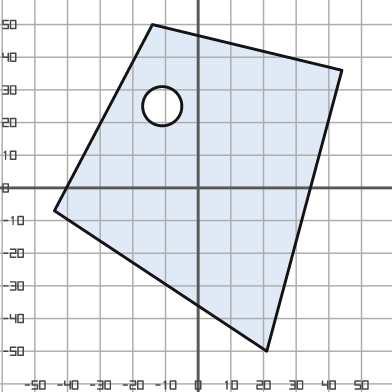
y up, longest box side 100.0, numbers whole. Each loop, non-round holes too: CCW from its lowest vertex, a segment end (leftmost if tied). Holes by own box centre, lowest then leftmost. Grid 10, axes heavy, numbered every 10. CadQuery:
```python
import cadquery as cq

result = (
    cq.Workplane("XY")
    .moveTo(21.0, -50.0)
    .lineTo(44.0, 36.0)
    .lineTo(-14.0, 50.0)
    .lineTo(-44.0, -7.0)
    .close()
    .moveTo(-11.0, 25.0)
    .circle(6.0)
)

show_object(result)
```